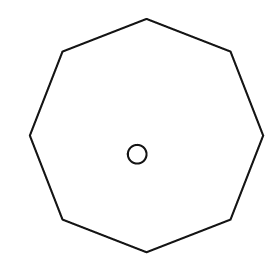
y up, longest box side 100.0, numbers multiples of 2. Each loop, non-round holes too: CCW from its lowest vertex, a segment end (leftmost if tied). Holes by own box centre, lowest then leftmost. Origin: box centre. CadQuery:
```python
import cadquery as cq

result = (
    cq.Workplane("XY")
    .moveTo(0.0, -50.0)
    .lineTo(36.0, -36.0)
    .lineTo(50.0, 0.0)
    .lineTo(36.0, 36.0)
    .lineTo(0.0, 50.0)
    .lineTo(-36.0, 36.0)
    .lineTo(-50.0, 0.0)
    .lineTo(-36.0, -36.0)
    .close()
    .moveTo(-4.0, -8.0)
    .circle(4.0)
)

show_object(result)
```